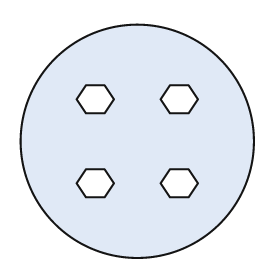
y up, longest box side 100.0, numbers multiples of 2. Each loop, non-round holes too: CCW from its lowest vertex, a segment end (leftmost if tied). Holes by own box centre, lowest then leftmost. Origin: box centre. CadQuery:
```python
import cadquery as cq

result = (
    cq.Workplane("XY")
    .moveTo(0.0, 0.0)
    .circle(50.0)
    .moveTo(-22.0, -24.0)
    .lineTo(-14.0, -24.0)
    .lineTo(-10.0, -18.0)
    .lineTo(-14.0, -12.0)
    .lineTo(-22.0, -12.0)
    .lineTo(-26.0, -18.0)
    .close()
    .moveTo(14.0, -24.0)
    .lineTo(22.0, -24.0)
    .lineTo(26.0, -18.0)
    .lineTo(22.0, -12.0)
    .lineTo(14.0, -12.0)
    .lineTo(10.0, -18.0)
    .close()
    .moveTo(-22.0, 12.0)
    .lineTo(-14.0, 12.0)
    .lineTo(-10.0, 18.0)
    .lineTo(-14.0, 24.0)
    .lineTo(-22.0, 24.0)
    .lineTo(-26.0, 18.0)
    .close()
    .moveTo(14.0, 12.0)
    .lineTo(22.0, 12.0)
    .lineTo(26.0, 18.0)
    .lineTo(22.0, 24.0)
    .lineTo(14.0, 24.0)
    .lineTo(10.0, 18.0)
    .close()
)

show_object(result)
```